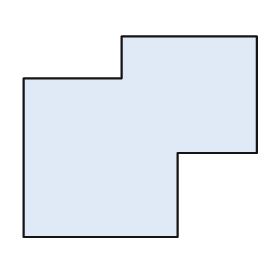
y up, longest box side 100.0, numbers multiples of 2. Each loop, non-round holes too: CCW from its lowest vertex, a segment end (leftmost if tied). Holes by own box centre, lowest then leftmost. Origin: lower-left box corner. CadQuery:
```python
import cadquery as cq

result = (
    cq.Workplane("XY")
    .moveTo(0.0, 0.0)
    .lineTo(66.0, 0.0)
    .lineTo(66.0, 36.0)
    .lineTo(100.0, 36.0)
    .lineTo(100.0, 86.0)
    .lineTo(42.0, 86.0)
    .lineTo(42.0, 68.0)
    .lineTo(0.0, 68.0)
    .close()
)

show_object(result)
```